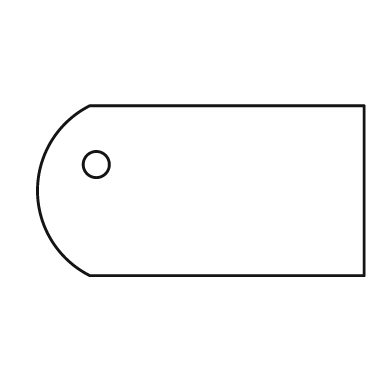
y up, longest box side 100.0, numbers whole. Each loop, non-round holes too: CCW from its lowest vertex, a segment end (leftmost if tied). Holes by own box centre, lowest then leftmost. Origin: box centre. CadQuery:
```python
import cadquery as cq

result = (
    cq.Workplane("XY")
    .moveTo(-34.0, -26.0)
    .lineTo(50.0, -26.0)
    .lineTo(50.0, 26.0)
    .lineTo(-34.0, 26.0)
    .threePointArc((-50.0, 0.0), (-34.0, -26.0))
    .close()
    .moveTo(-32.0, 8.0)
    .circle(4.0)
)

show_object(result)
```